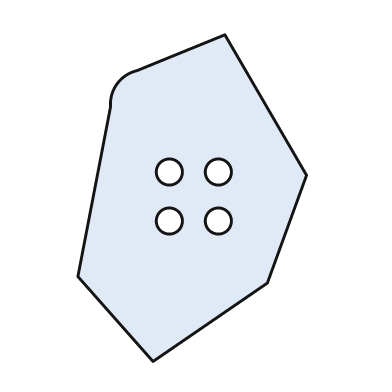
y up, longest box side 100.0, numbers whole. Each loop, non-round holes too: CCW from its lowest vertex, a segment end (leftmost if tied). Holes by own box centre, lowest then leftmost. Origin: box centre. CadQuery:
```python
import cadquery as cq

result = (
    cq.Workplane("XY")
    .moveTo(-12.0, -50.0)
    .lineTo(23.0, -26.0)
    .lineTo(35.0, 7.0)
    .lineTo(10.0, 50.0)
    .lineTo(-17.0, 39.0)
    .threePointArc((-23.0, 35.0), (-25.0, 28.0))
    .lineTo(-35.0, -24.0)
    .close()
    .moveTo(-7.0, -7.0)
    .circle(4.0)
    .moveTo(8.0, -7.0)
    .circle(4.0)
    .moveTo(-7.0, 8.0)
    .circle(4.0)
    .moveTo(8.0, 8.0)
    .circle(4.0)
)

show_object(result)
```